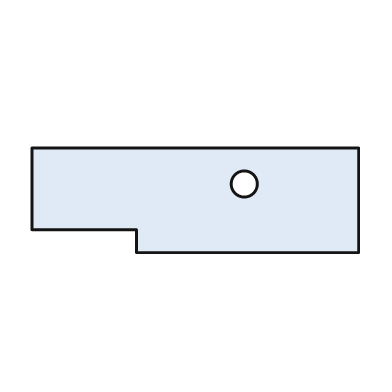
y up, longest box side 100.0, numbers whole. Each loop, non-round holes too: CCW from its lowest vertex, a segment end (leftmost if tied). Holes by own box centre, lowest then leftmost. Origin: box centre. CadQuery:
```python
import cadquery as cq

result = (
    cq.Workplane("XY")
    .moveTo(-18.0, -16.0)
    .lineTo(50.0, -16.0)
    .lineTo(50.0, 16.0)
    .lineTo(-50.0, 16.0)
    .lineTo(-50.0, -9.0)
    .lineTo(-18.0, -9.0)
    .close()
    .moveTo(15.0, 5.0)
    .circle(4.0)
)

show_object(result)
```